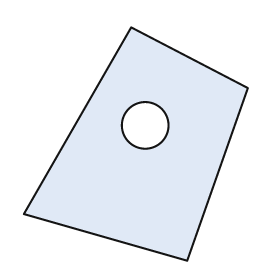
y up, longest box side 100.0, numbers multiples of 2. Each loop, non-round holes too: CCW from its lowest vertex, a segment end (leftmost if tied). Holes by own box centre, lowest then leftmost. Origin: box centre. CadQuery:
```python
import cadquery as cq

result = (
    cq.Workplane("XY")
    .moveTo(22.0, -50.0)
    .lineTo(48.0, 24.0)
    .lineTo(-2.0, 50.0)
    .lineTo(-48.0, -30.0)
    .close()
    .moveTo(4.0, 8.0)
    .circle(10.0)
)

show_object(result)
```